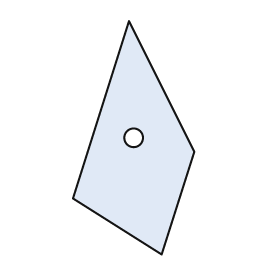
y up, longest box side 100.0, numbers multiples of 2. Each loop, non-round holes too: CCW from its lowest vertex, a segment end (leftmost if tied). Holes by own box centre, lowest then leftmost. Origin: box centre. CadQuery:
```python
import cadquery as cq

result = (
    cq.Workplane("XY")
    .moveTo(12.0, -50.0)
    .lineTo(26.0, -6.0)
    .lineTo(-2.0, 50.0)
    .lineTo(-26.0, -26.0)
    .close()
    .moveTo(0.0, 0.0)
    .circle(4.0)
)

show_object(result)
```